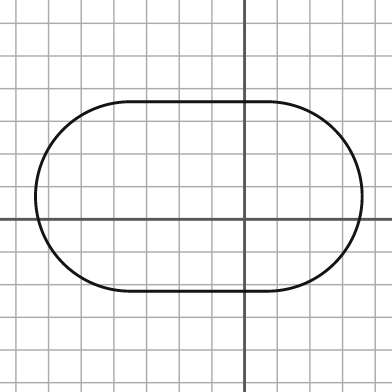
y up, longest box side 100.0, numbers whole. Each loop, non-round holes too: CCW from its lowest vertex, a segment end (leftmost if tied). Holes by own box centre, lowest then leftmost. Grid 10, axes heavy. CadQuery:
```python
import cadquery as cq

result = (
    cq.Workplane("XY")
    .moveTo(-35.0, -22.0)
    .lineTo(7.0, -22.0)
    .threePointArc((36.0, 7.0), (7.0, 36.0))
    .lineTo(-35.0, 36.0)
    .threePointArc((-64.0, 7.0), (-35.0, -22.0))
    .close()
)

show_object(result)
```